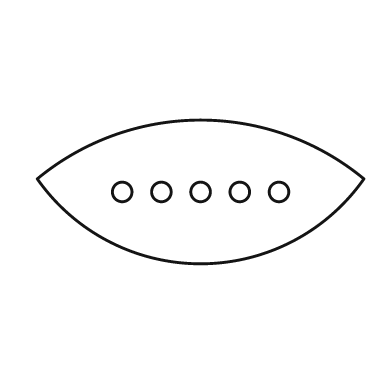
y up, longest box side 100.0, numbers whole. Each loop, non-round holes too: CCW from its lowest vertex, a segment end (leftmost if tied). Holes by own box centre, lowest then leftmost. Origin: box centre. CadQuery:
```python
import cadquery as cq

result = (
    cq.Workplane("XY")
    .moveTo(-50.0, 4.0)
    .threePointArc((0.0, -22.0), (50.0, 4.0))
    .threePointArc((0.0, 22.0), (-50.0, 4.0))
    .close()
    .moveTo(-24.0, 0.0)
    .circle(3.0)
    .moveTo(-12.0, 0.0)
    .circle(3.0)
    .moveTo(0.0, 0.0)
    .circle(3.0)
    .moveTo(12.0, 0.0)
    .circle(3.0)
    .moveTo(24.0, 0.0)
    .circle(3.0)
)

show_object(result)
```